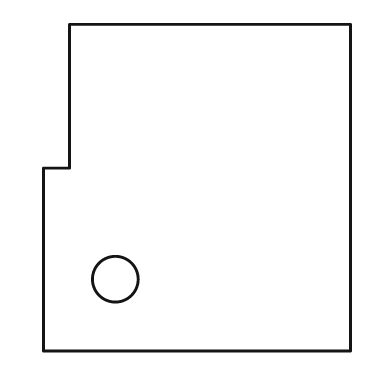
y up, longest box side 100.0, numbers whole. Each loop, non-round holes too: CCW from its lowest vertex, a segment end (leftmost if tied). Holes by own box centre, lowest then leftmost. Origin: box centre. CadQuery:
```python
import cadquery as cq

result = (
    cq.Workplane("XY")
    .moveTo(-47.0, -50.0)
    .lineTo(47.0, -50.0)
    .lineTo(47.0, 50.0)
    .lineTo(-39.0, 50.0)
    .lineTo(-39.0, 6.0)
    .lineTo(-47.0, 6.0)
    .close()
    .moveTo(-25.0, -28.0)
    .circle(7.0)
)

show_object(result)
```